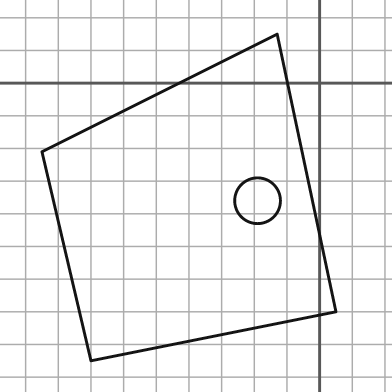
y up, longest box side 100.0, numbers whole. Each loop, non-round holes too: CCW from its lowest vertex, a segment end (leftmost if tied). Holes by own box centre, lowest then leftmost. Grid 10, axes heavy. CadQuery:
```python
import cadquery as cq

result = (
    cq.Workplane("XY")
    .moveTo(-70.0, -85.0)
    .lineTo(5.0, -70.0)
    .lineTo(-13.0, 15.0)
    .lineTo(-85.0, -21.0)
    .close()
    .moveTo(-19.0, -36.0)
    .circle(7.0)
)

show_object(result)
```